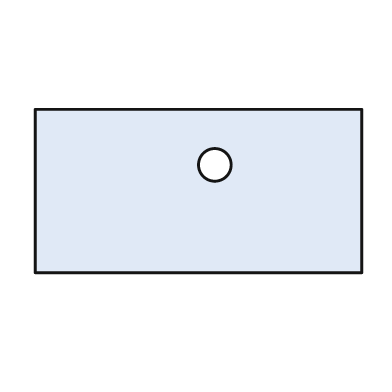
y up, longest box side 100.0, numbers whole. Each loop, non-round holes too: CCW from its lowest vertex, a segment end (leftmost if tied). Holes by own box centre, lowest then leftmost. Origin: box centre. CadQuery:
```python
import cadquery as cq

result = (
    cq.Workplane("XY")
    .moveTo(-50.0, -25.0)
    .lineTo(50.0, -25.0)
    .lineTo(50.0, 25.0)
    .lineTo(-50.0, 25.0)
    .close()
    .moveTo(5.0, 8.0)
    .circle(5.0)
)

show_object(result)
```